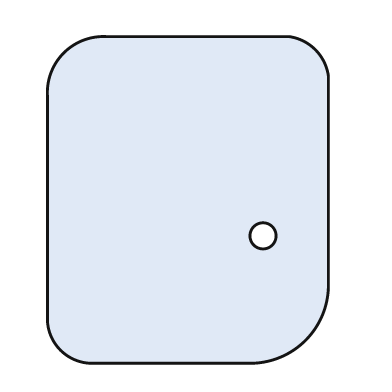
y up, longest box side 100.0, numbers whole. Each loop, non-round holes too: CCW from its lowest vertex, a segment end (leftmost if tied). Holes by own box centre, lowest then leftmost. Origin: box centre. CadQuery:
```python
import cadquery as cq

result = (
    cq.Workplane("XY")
    .moveTo(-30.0, -50.0)
    .lineTo(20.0, -50.0)
    .threePointArc((36.0, -43.0), (43.0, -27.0))
    .lineTo(43.0, 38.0)
    .threePointArc((39.0, 46.0), (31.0, 50.0))
    .lineTo(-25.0, 50.0)
    .threePointArc((-38.0, 45.0), (-43.0, 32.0))
    .lineTo(-43.0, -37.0)
    .threePointArc((-39.0, -46.0), (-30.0, -50.0))
    .close()
    .moveTo(23.0, -11.0)
    .circle(4.0)
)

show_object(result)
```